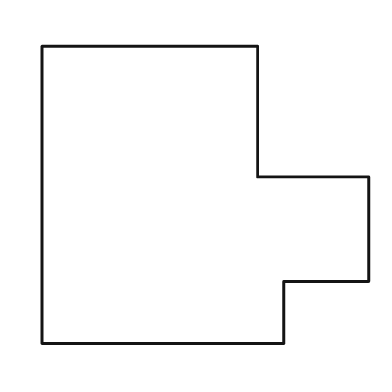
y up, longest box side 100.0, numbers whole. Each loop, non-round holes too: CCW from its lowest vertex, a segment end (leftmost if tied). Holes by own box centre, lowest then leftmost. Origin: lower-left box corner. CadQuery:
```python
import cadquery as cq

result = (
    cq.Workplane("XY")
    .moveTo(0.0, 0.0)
    .lineTo(74.0, 0.0)
    .lineTo(74.0, 19.0)
    .lineTo(100.0, 19.0)
    .lineTo(100.0, 51.0)
    .lineTo(66.0, 51.0)
    .lineTo(66.0, 91.0)
    .lineTo(0.0, 91.0)
    .close()
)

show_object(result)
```